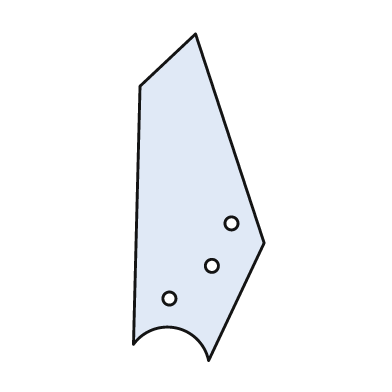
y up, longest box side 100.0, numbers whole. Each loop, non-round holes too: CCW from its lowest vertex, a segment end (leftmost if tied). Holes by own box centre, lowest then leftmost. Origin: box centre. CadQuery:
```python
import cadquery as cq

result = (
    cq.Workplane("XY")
    .moveTo(3.0, -50.0)
    .lineTo(20.0, -14.0)
    .lineTo(-1.0, 50.0)
    .lineTo(-18.0, 34.0)
    .lineTo(-20.0, -45.0)
    .threePointArc((-7.0, -40.0), (3.0, -50.0))
    .close()
    .moveTo(-9.0, -31.0)
    .circle(2.0)
    .moveTo(4.0, -21.0)
    .circle(2.0)
    .moveTo(10.0, -8.0)
    .circle(2.0)
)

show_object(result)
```